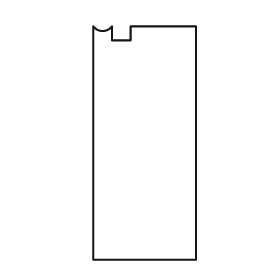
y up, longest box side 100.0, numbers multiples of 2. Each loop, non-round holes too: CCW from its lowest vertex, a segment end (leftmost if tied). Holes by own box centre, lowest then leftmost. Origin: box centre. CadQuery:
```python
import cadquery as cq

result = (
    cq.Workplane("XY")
    .moveTo(-22.0, -50.0)
    .lineTo(22.0, -50.0)
    .lineTo(22.0, 50.0)
    .lineTo(-6.0, 50.0)
    .lineTo(-6.0, 44.0)
    .lineTo(-14.0, 44.0)
    .lineTo(-14.0, 50.0)
    .threePointArc((-18.0, 48.0), (-22.0, 50.0))
    .close()
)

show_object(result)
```